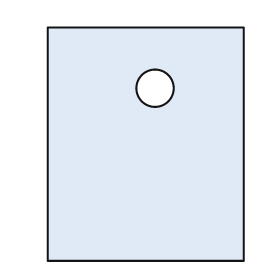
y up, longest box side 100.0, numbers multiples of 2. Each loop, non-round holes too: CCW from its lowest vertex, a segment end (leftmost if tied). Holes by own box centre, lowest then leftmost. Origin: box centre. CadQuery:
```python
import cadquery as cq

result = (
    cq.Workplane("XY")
    .moveTo(-42.0, -50.0)
    .lineTo(42.0, -50.0)
    .lineTo(42.0, 50.0)
    .lineTo(-42.0, 50.0)
    .close()
    .moveTo(4.0, 24.0)
    .circle(8.0)
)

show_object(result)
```